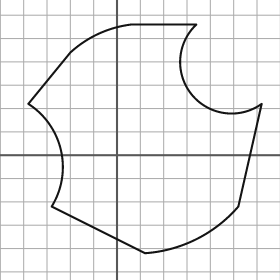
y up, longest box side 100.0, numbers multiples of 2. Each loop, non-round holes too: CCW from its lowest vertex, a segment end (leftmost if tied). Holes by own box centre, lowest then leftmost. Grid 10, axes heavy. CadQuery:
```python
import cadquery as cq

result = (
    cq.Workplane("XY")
    .moveTo(12.0, -42.0)
    .threePointArc((34.0, -36.0), (52.0, -22.0))
    .lineTo(62.0, 22.0)
    .threePointArc((32.0, 26.0), (34.0, 56.0))
    .lineTo(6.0, 56.0)
    .threePointArc((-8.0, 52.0), (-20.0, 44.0))
    .lineTo(-38.0, 22.0)
    .threePointArc((-24.0, 2.0), (-28.0, -22.0))
    .close()
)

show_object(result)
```